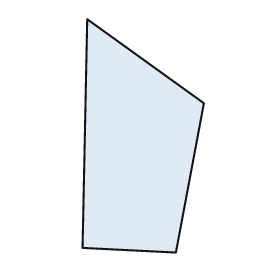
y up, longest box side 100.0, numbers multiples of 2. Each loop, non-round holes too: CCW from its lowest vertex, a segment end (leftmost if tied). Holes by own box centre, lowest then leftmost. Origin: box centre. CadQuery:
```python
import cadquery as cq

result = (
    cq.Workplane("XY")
    .moveTo(14.0, -50.0)
    .lineTo(26.0, 14.0)
    .lineTo(-24.0, 50.0)
    .lineTo(-26.0, -48.0)
    .close()
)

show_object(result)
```